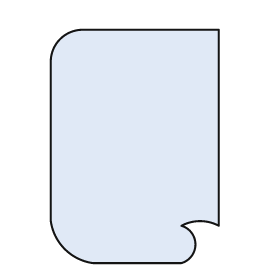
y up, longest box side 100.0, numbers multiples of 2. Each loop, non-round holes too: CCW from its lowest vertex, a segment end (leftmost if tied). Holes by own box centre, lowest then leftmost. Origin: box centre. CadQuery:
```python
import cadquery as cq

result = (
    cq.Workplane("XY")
    .moveTo(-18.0, -50.0)
    .lineTo(20.0, -50.0)
    .threePointArc((26.0, -42.0), (20.0, -34.0))
    .threePointArc((28.0, -32.0), (36.0, -34.0))
    .lineTo(36.0, 50.0)
    .lineTo(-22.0, 50.0)
    .threePointArc((-32.0, 46.0), (-36.0, 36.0))
    .lineTo(-36.0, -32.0)
    .threePointArc((-30.0, -44.0), (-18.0, -50.0))
    .close()
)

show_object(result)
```